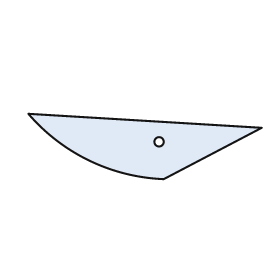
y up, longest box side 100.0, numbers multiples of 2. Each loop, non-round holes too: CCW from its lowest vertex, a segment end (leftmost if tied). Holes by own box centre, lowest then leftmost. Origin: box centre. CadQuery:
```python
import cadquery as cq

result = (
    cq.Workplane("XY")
    .moveTo(8.0, -14.0)
    .lineTo(50.0, 8.0)
    .lineTo(-50.0, 14.0)
    .threePointArc((-24.0, -6.0), (8.0, -14.0))
    .close()
    .moveTo(6.0, 2.0)
    .circle(2.0)
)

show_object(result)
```